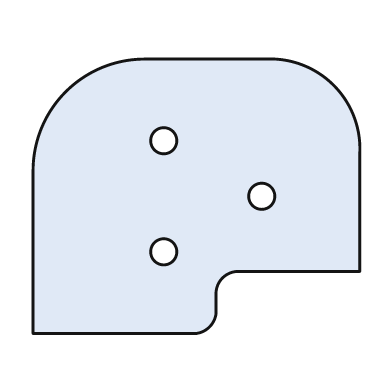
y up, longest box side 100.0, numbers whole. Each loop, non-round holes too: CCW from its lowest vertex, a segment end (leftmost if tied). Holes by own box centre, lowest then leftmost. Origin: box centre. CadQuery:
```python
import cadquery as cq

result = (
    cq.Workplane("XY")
    .moveTo(-50.0, -42.0)
    .lineTo(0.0, -42.0)
    .threePointArc((4.0, -40.0), (6.0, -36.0))
    .lineTo(6.0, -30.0)
    .threePointArc((8.0, -25.0), (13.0, -23.0))
    .lineTo(50.0, -23.0)
    .lineTo(50.0, 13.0)
    .threePointArc((42.0, 34.0), (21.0, 42.0))
    .lineTo(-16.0, 42.0)
    .threePointArc((-40.0, 32.0), (-50.0, 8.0))
    .close()
    .moveTo(-10.0, -17.0)
    .circle(4.0)
    .moveTo(20.0, 0.0)
    .circle(4.0)
    .moveTo(-10.0, 17.0)
    .circle(4.0)
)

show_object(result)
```